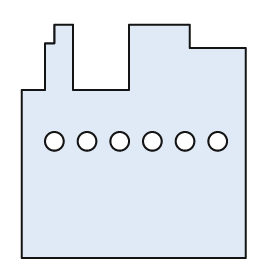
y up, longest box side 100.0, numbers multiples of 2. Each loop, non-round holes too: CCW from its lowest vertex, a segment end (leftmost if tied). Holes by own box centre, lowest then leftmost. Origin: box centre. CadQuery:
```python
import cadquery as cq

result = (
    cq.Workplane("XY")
    .moveTo(-48.0, -50.0)
    .lineTo(48.0, -50.0)
    .lineTo(48.0, 40.0)
    .lineTo(24.0, 40.0)
    .lineTo(24.0, 50.0)
    .lineTo(-2.0, 50.0)
    .lineTo(-2.0, 22.0)
    .lineTo(-26.0, 22.0)
    .lineTo(-26.0, 50.0)
    .lineTo(-34.0, 50.0)
    .lineTo(-34.0, 42.0)
    .lineTo(-38.0, 42.0)
    .lineTo(-38.0, 22.0)
    .lineTo(-48.0, 22.0)
    .close()
    .moveTo(-34.0, 0.0)
    .circle(4.0)
    .moveTo(-20.0, 0.0)
    .circle(4.0)
    .moveTo(-6.0, 0.0)
    .circle(4.0)
    .moveTo(8.0, 0.0)
    .circle(4.0)
    .moveTo(22.0, 0.0)
    .circle(4.0)
    .moveTo(36.0, 0.0)
    .circle(4.0)
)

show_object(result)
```